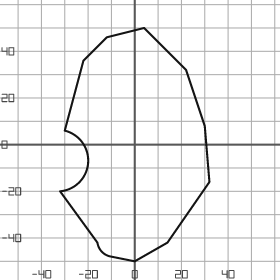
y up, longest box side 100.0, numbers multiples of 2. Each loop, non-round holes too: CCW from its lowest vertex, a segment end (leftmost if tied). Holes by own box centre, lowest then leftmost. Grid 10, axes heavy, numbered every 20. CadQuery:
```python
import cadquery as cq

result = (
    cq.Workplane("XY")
    .moveTo(0.0, -50.0)
    .lineTo(14.0, -42.0)
    .lineTo(32.0, -16.0)
    .lineTo(30.0, 8.0)
    .lineTo(22.0, 32.0)
    .lineTo(4.0, 50.0)
    .lineTo(-12.0, 46.0)
    .lineTo(-22.0, 36.0)
    .lineTo(-30.0, 6.0)
    .threePointArc((-20.0, -8.0), (-32.0, -20.0))
    .lineTo(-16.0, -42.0)
    .threePointArc((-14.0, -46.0), (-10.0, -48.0))
    .close()
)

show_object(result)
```